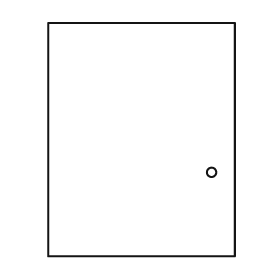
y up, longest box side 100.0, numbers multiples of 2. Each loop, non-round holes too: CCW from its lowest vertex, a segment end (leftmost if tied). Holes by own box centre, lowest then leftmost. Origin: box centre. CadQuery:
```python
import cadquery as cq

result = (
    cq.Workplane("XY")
    .moveTo(-40.0, -50.0)
    .lineTo(40.0, -50.0)
    .lineTo(40.0, 50.0)
    .lineTo(-40.0, 50.0)
    .close()
    .moveTo(30.0, -14.0)
    .circle(2.0)
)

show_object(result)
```